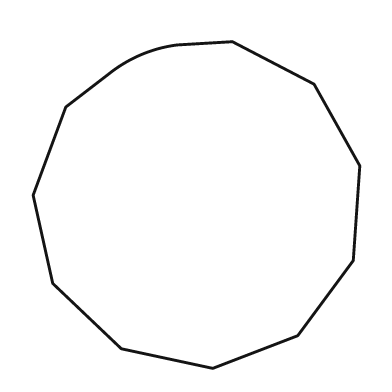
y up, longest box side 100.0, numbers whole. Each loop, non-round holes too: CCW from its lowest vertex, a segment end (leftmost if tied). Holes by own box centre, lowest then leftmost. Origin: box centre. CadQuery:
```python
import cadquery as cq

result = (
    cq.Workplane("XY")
    .moveTo(5.0, -50.0)
    .lineTo(31.0, -40.0)
    .lineTo(48.0, -17.0)
    .lineTo(50.0, 12.0)
    .lineTo(36.0, 37.0)
    .lineTo(11.0, 50.0)
    .lineTo(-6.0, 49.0)
    .threePointArc((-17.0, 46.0), (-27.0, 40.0))
    .lineTo(-40.0, 30.0)
    .lineTo(-50.0, 3.0)
    .lineTo(-44.0, -24.0)
    .lineTo(-23.0, -44.0)
    .close()
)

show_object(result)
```